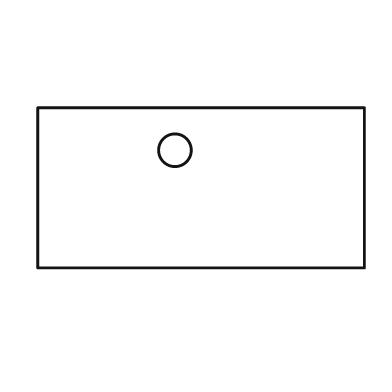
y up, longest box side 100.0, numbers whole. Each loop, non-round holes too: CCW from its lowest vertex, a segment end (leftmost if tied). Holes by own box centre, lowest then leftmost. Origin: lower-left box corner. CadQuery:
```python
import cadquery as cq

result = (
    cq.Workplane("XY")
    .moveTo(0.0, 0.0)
    .lineTo(100.0, 0.0)
    .lineTo(100.0, 49.0)
    .lineTo(0.0, 49.0)
    .close()
    .moveTo(42.0, 36.0)
    .circle(5.0)
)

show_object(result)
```